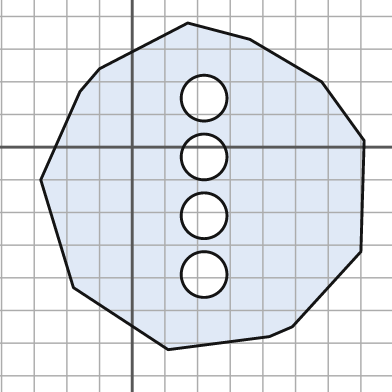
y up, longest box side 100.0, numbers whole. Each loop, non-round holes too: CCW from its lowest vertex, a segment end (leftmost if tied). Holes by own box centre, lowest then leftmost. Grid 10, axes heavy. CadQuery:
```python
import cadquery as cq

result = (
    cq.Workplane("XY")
    .moveTo(11.0, -62.0)
    .lineTo(42.0, -58.0)
    .lineTo(49.0, -55.0)
    .lineTo(70.0, -32.0)
    .lineTo(71.0, 2.0)
    .lineTo(58.0, 20.0)
    .lineTo(36.0, 33.0)
    .lineTo(17.0, 38.0)
    .lineTo(-10.0, 24.0)
    .lineTo(-16.0, 17.0)
    .lineTo(-28.0, -10.0)
    .lineTo(-18.0, -43.0)
    .close()
    .moveTo(22.0, -39.0)
    .circle(7.0)
    .moveTo(22.0, -21.0)
    .circle(7.0)
    .moveTo(22.0, -3.0)
    .circle(7.0)
    .moveTo(22.0, 15.0)
    .circle(7.0)
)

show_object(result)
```